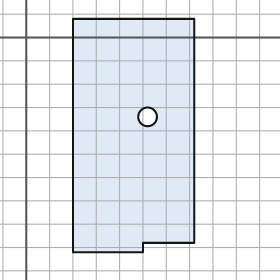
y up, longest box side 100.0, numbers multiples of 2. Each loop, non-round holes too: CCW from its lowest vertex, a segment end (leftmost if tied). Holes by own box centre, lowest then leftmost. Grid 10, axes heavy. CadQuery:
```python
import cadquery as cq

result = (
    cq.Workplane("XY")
    .moveTo(20.0, -92.0)
    .lineTo(50.0, -92.0)
    .lineTo(50.0, -88.0)
    .lineTo(72.0, -88.0)
    .lineTo(72.0, 8.0)
    .lineTo(20.0, 8.0)
    .close()
    .moveTo(52.0, -34.0)
    .circle(4.0)
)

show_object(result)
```